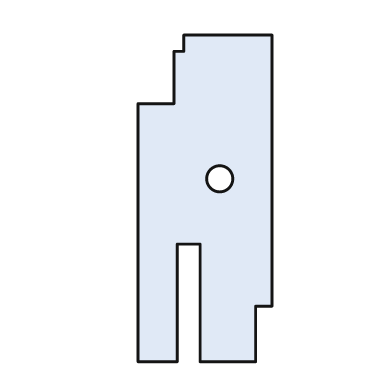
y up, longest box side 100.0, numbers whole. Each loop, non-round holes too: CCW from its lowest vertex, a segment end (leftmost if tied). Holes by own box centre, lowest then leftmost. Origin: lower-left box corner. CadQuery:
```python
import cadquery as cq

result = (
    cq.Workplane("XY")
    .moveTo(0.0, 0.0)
    .lineTo(12.0, 0.0)
    .lineTo(12.0, 36.0)
    .lineTo(19.0, 36.0)
    .lineTo(19.0, 0.0)
    .lineTo(36.0, 0.0)
    .lineTo(36.0, 17.0)
    .lineTo(41.0, 17.0)
    .lineTo(41.0, 100.0)
    .lineTo(14.0, 100.0)
    .lineTo(14.0, 95.0)
    .lineTo(11.0, 95.0)
    .lineTo(11.0, 79.0)
    .lineTo(0.0, 79.0)
    .close()
    .moveTo(25.0, 56.0)
    .circle(4.0)
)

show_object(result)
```